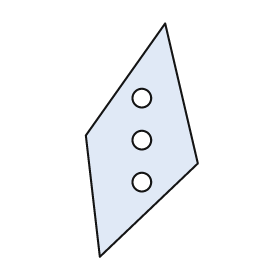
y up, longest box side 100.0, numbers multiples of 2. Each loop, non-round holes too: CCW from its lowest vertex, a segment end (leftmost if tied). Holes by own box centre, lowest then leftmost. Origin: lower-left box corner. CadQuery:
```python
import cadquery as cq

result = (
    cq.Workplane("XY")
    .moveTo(6.0, 0.0)
    .lineTo(48.0, 40.0)
    .lineTo(34.0, 100.0)
    .lineTo(0.0, 52.0)
    .close()
    .moveTo(24.0, 32.0)
    .circle(4.0)
    .moveTo(24.0, 50.0)
    .circle(4.0)
    .moveTo(24.0, 68.0)
    .circle(4.0)
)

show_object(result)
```